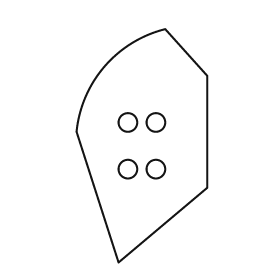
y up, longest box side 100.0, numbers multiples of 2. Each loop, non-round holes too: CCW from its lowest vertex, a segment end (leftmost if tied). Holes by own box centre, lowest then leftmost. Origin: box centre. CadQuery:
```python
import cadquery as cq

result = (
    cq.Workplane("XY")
    .moveTo(-10.0, -50.0)
    .lineTo(28.0, -18.0)
    .lineTo(28.0, 30.0)
    .lineTo(10.0, 50.0)
    .threePointArc((-16.0, 34.0), (-28.0, 6.0))
    .close()
    .moveTo(-6.0, -10.0)
    .circle(4.0)
    .moveTo(6.0, -10.0)
    .circle(4.0)
    .moveTo(-6.0, 10.0)
    .circle(4.0)
    .moveTo(6.0, 10.0)
    .circle(4.0)
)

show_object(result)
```